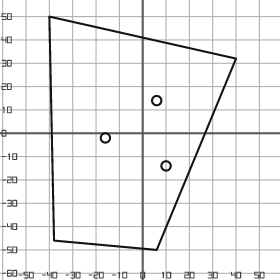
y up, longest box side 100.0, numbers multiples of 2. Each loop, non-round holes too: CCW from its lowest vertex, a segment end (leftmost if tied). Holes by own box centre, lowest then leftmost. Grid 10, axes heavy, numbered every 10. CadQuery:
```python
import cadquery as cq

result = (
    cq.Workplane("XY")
    .moveTo(6.0, -50.0)
    .lineTo(40.0, 32.0)
    .lineTo(-40.0, 50.0)
    .lineTo(-38.0, -46.0)
    .close()
    .moveTo(10.0, -14.0)
    .circle(2.0)
    .moveTo(-16.0, -2.0)
    .circle(2.0)
    .moveTo(6.0, 14.0)
    .circle(2.0)
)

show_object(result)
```